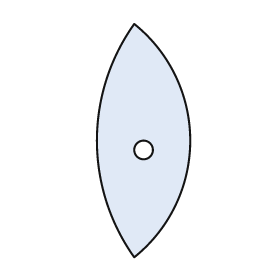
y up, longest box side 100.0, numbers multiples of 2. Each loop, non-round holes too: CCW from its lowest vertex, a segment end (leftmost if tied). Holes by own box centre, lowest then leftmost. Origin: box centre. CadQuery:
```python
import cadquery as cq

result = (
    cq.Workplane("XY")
    .moveTo(-4.0, -50.0)
    .threePointArc((20.0, 0.0), (-4.0, 50.0))
    .threePointArc((-20.0, 0.0), (-4.0, -50.0))
    .close()
    .moveTo(0.0, -4.0)
    .circle(4.0)
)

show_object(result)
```